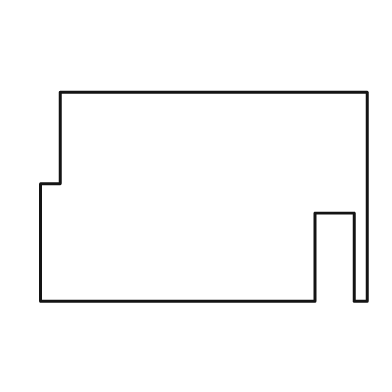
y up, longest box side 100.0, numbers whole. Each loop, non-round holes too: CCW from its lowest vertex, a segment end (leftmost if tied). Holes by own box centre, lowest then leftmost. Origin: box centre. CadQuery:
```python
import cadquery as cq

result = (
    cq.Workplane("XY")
    .moveTo(-50.0, -32.0)
    .lineTo(34.0, -32.0)
    .lineTo(34.0, -5.0)
    .lineTo(46.0, -5.0)
    .lineTo(46.0, -32.0)
    .lineTo(50.0, -32.0)
    .lineTo(50.0, 32.0)
    .lineTo(-44.0, 32.0)
    .lineTo(-44.0, 4.0)
    .lineTo(-50.0, 4.0)
    .close()
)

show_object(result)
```